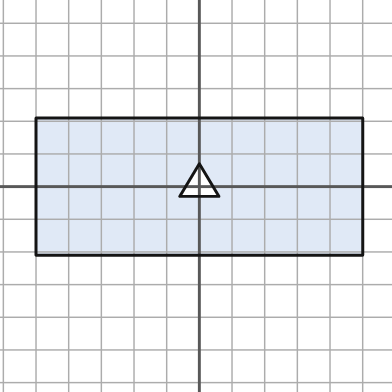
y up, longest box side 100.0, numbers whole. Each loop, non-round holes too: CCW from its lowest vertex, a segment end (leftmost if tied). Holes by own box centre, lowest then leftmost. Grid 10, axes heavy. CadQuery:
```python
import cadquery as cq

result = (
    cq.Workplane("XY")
    .moveTo(-50.0, -21.0)
    .lineTo(50.0, -21.0)
    .lineTo(50.0, 21.0)
    .lineTo(-50.0, 21.0)
    .close()
    .moveTo(-6.0, -3.0)
    .lineTo(6.0, -3.0)
    .lineTo(0.0, 7.0)
    .close()
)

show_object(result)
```